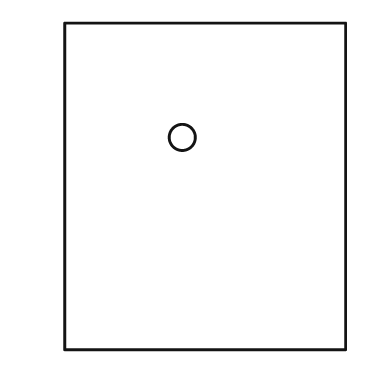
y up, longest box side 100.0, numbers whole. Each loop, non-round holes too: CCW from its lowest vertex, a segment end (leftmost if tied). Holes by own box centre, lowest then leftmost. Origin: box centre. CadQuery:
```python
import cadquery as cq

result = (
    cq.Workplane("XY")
    .moveTo(-43.0, -50.0)
    .lineTo(43.0, -50.0)
    .lineTo(43.0, 50.0)
    .lineTo(-43.0, 50.0)
    .close()
    .moveTo(-7.0, 15.0)
    .circle(4.0)
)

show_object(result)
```